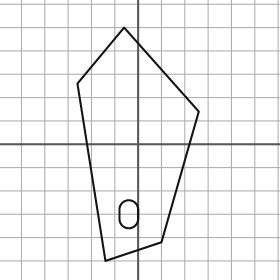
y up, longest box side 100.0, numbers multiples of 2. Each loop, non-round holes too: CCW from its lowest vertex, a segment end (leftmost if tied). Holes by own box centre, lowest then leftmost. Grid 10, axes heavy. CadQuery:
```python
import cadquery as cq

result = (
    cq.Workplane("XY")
    .moveTo(-14.0, -50.0)
    .lineTo(10.0, -42.0)
    .lineTo(26.0, 14.0)
    .lineTo(-6.0, 50.0)
    .lineTo(-26.0, 26.0)
    .close()
    .moveTo(-8.0, -32.0)
    .threePointArc((-4.0, -36.0), (0.0, -32.0))
    .lineTo(0.0, -28.0)
    .threePointArc((-4.0, -24.0), (-8.0, -28.0))
    .close()
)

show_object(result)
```